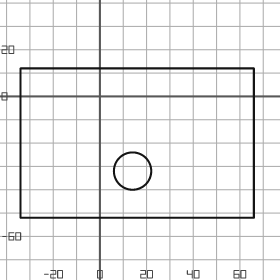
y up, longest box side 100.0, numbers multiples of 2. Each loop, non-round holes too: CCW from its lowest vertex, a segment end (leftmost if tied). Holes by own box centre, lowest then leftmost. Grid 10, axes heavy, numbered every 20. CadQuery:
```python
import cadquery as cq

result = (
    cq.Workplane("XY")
    .moveTo(-34.0, -52.0)
    .lineTo(66.0, -52.0)
    .lineTo(66.0, 12.0)
    .lineTo(-34.0, 12.0)
    .close()
    .moveTo(14.0, -32.0)
    .circle(8.0)
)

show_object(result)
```